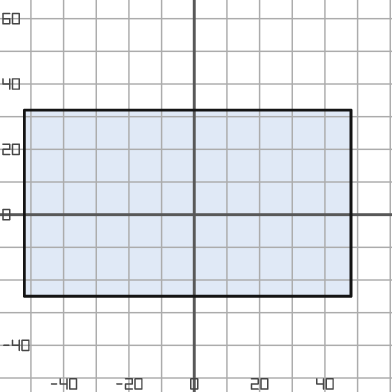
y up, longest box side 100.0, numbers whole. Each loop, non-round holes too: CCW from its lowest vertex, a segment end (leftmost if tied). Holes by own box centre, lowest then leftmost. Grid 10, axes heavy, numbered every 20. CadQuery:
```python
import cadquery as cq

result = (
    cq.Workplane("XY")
    .moveTo(-52.0, -25.0)
    .lineTo(48.0, -25.0)
    .lineTo(48.0, 32.0)
    .lineTo(-52.0, 32.0)
    .close()
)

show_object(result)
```